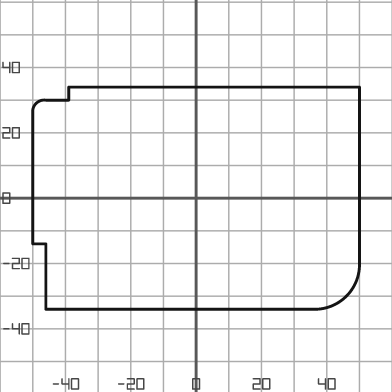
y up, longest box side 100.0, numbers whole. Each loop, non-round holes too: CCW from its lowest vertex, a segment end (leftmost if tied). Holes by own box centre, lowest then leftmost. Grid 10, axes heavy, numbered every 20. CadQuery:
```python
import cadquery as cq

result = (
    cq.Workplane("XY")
    .moveTo(-46.0, -34.0)
    .lineTo(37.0, -34.0)
    .threePointArc((46.0, -30.0), (50.0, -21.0))
    .lineTo(50.0, 34.0)
    .lineTo(-39.0, 34.0)
    .lineTo(-39.0, 30.0)
    .lineTo(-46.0, 30.0)
    .threePointArc((-49.0, 29.0), (-50.0, 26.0))
    .lineTo(-50.0, -14.0)
    .lineTo(-46.0, -14.0)
    .close()
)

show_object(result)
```